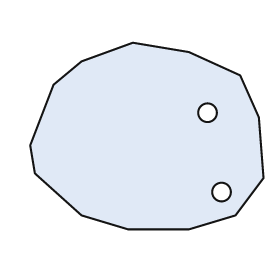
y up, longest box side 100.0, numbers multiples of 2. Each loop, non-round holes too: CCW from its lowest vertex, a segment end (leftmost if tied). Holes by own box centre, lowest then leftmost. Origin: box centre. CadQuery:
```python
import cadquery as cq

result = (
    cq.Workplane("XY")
    .moveTo(-8.0, -40.0)
    .lineTo(18.0, -40.0)
    .lineTo(38.0, -34.0)
    .lineTo(50.0, -18.0)
    .lineTo(48.0, 8.0)
    .lineTo(40.0, 26.0)
    .lineTo(18.0, 36.0)
    .lineTo(-6.0, 40.0)
    .lineTo(-28.0, 32.0)
    .lineTo(-40.0, 22.0)
    .lineTo(-50.0, -4.0)
    .lineTo(-48.0, -16.0)
    .lineTo(-28.0, -34.0)
    .close()
    .moveTo(32.0, -24.0)
    .circle(4.0)
    .moveTo(26.0, 10.0)
    .circle(4.0)
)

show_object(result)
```